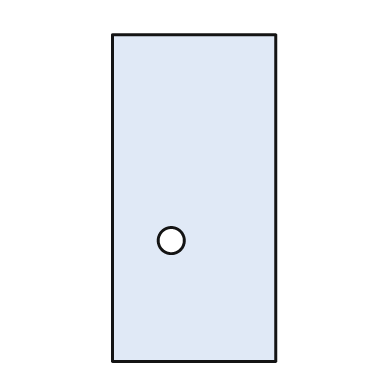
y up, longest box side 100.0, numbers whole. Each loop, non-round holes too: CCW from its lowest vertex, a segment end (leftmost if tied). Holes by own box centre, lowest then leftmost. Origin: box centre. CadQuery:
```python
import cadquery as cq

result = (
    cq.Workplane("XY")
    .moveTo(-25.0, -50.0)
    .lineTo(25.0, -50.0)
    .lineTo(25.0, 50.0)
    .lineTo(-25.0, 50.0)
    .close()
    .moveTo(-7.0, -13.0)
    .circle(4.0)
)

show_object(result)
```